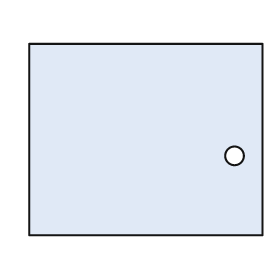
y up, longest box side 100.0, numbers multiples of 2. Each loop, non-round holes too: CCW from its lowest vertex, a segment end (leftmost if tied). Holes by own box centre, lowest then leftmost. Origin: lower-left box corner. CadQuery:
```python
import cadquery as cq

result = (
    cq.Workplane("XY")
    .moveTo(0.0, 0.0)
    .lineTo(100.0, 0.0)
    .lineTo(100.0, 82.0)
    .lineTo(0.0, 82.0)
    .close()
    .moveTo(88.0, 34.0)
    .circle(4.0)
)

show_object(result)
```